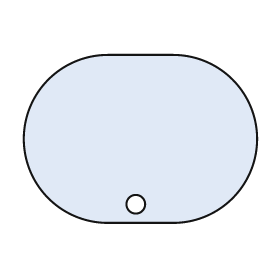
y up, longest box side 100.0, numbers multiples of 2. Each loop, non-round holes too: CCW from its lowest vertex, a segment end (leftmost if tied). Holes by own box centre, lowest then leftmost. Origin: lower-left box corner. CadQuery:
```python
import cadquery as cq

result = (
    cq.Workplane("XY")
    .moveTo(36.0, 0.0)
    .lineTo(64.0, 0.0)
    .threePointArc((100.0, 36.0), (64.0, 72.0))
    .lineTo(36.0, 72.0)
    .threePointArc((0.0, 36.0), (36.0, 0.0))
    .close()
    .moveTo(48.0, 8.0)
    .circle(4.0)
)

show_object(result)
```